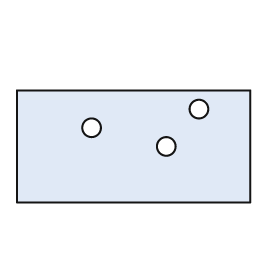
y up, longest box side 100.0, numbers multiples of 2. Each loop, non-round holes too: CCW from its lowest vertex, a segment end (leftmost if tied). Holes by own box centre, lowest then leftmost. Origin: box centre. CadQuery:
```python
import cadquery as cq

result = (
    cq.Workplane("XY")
    .moveTo(-50.0, -24.0)
    .lineTo(50.0, -24.0)
    .lineTo(50.0, 24.0)
    .lineTo(-50.0, 24.0)
    .close()
    .moveTo(14.0, 0.0)
    .circle(4.0)
    .moveTo(-18.0, 8.0)
    .circle(4.0)
    .moveTo(28.0, 16.0)
    .circle(4.0)
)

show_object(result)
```